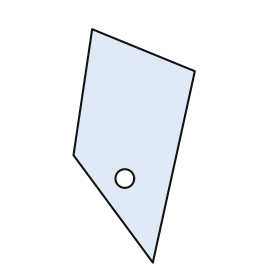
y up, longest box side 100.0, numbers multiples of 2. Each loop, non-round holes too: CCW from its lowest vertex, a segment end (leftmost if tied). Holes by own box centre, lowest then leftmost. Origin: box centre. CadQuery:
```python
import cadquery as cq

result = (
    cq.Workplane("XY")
    .moveTo(8.0, -50.0)
    .lineTo(26.0, 32.0)
    .lineTo(-18.0, 50.0)
    .lineTo(-26.0, -4.0)
    .close()
    .moveTo(-4.0, -14.0)
    .circle(4.0)
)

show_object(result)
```